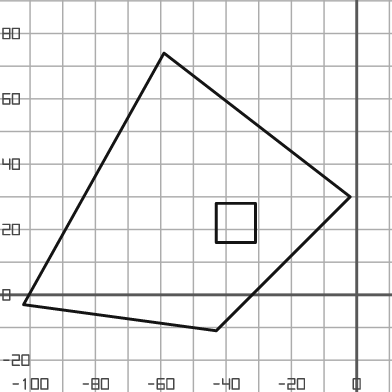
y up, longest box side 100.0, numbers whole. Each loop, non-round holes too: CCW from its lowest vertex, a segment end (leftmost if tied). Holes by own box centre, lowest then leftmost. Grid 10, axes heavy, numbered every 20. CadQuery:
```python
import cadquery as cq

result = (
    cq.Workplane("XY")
    .moveTo(-43.0, -11.0)
    .lineTo(-2.0, 30.0)
    .lineTo(-59.0, 74.0)
    .lineTo(-102.0, -3.0)
    .close()
    .moveTo(-43.0, 16.0)
    .lineTo(-31.0, 16.0)
    .lineTo(-31.0, 28.0)
    .lineTo(-43.0, 28.0)
    .close()
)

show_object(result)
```